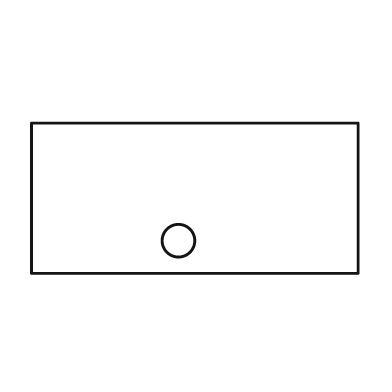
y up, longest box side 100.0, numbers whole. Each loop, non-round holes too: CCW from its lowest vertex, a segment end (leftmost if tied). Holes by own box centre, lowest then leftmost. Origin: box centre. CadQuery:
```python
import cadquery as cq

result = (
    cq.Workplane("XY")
    .moveTo(-50.0, -23.0)
    .lineTo(50.0, -23.0)
    .lineTo(50.0, 23.0)
    .lineTo(-50.0, 23.0)
    .close()
    .moveTo(-5.0, -13.0)
    .circle(5.0)
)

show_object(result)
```